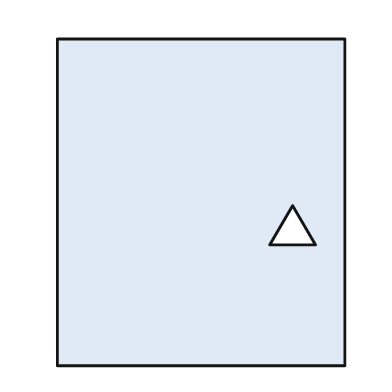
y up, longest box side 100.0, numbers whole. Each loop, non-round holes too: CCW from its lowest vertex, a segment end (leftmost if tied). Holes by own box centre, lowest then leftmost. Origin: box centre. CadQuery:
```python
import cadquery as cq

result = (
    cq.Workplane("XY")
    .moveTo(-44.0, -50.0)
    .lineTo(44.0, -50.0)
    .lineTo(44.0, 50.0)
    .lineTo(-44.0, 50.0)
    .close()
    .moveTo(21.0, -13.0)
    .lineTo(35.0, -13.0)
    .lineTo(28.0, -1.0)
    .close()
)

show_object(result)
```